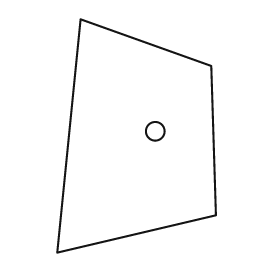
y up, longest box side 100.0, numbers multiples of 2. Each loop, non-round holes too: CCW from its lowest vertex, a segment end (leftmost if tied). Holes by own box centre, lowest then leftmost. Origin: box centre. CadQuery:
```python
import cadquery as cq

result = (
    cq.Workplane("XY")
    .moveTo(-34.0, -50.0)
    .lineTo(34.0, -34.0)
    .lineTo(32.0, 30.0)
    .lineTo(-24.0, 50.0)
    .close()
    .moveTo(8.0, 2.0)
    .circle(4.0)
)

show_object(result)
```